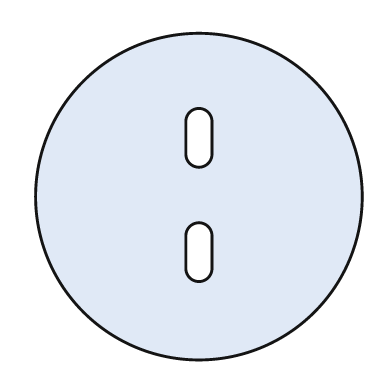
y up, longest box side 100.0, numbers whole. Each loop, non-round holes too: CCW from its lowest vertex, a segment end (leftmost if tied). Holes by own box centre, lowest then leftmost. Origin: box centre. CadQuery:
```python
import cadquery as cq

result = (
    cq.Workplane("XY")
    .moveTo(0.0, 0.0)
    .circle(50.0)
    .moveTo(-4.0, -22.0)
    .threePointArc((0.0, -26.0), (4.0, -22.0))
    .lineTo(4.0, -12.0)
    .threePointArc((0.0, -8.0), (-4.0, -12.0))
    .close()
    .moveTo(-4.0, 13.0)
    .threePointArc((0.0, 9.0), (4.0, 13.0))
    .lineTo(4.0, 23.0)
    .threePointArc((0.0, 27.0), (-4.0, 23.0))
    .close()
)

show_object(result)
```